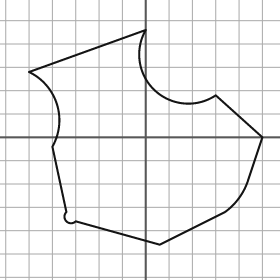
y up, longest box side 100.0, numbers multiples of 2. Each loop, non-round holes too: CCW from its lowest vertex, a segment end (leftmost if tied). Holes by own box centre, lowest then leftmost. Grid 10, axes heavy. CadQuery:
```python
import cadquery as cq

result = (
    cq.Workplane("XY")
    .moveTo(6.0, -46.0)
    .lineTo(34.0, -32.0)
    .threePointArc((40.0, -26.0), (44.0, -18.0))
    .lineTo(50.0, 0.0)
    .lineTo(30.0, 18.0)
    .threePointArc((4.0, 20.0), (0.0, 46.0))
    .lineTo(-50.0, 28.0)
    .threePointArc((-38.0, 14.0), (-40.0, -4.0))
    .lineTo(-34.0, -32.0)
    .threePointArc((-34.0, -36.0), (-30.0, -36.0))
    .close()
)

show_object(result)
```